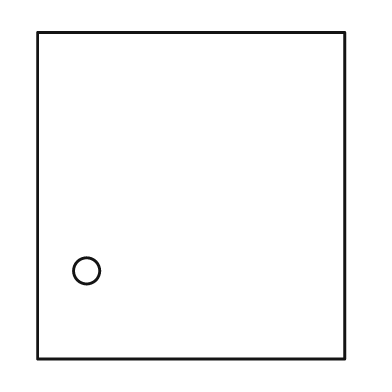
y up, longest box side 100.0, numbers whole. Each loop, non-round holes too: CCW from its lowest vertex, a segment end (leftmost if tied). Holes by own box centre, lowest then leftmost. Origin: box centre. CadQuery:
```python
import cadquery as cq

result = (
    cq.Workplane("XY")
    .moveTo(-47.0, -50.0)
    .lineTo(47.0, -50.0)
    .lineTo(47.0, 50.0)
    .lineTo(-47.0, 50.0)
    .close()
    .moveTo(-32.0, -23.0)
    .circle(4.0)
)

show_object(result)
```